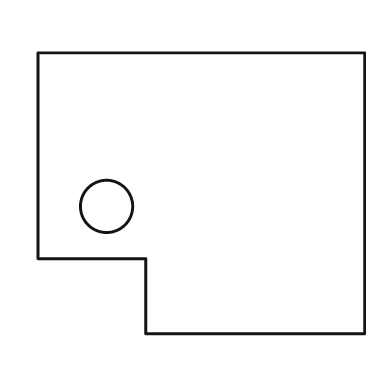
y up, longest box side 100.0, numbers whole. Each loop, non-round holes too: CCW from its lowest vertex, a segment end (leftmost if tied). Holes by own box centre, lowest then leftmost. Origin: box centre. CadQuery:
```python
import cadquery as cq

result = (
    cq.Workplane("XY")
    .moveTo(-17.0, -43.0)
    .lineTo(50.0, -43.0)
    .lineTo(50.0, 43.0)
    .lineTo(-50.0, 43.0)
    .lineTo(-50.0, -20.0)
    .lineTo(-17.0, -20.0)
    .close()
    .moveTo(-29.0, -4.0)
    .circle(8.0)
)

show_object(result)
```